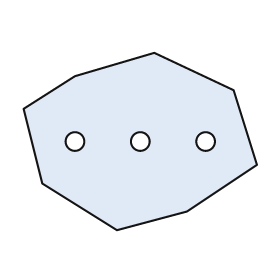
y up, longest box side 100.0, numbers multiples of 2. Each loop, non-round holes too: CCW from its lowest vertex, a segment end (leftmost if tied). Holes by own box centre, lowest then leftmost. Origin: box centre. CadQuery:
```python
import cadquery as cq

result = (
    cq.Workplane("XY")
    .moveTo(-10.0, -38.0)
    .lineTo(20.0, -30.0)
    .lineTo(50.0, -10.0)
    .lineTo(40.0, 22.0)
    .lineTo(6.0, 38.0)
    .lineTo(-28.0, 28.0)
    .lineTo(-50.0, 14.0)
    .lineTo(-42.0, -18.0)
    .close()
    .moveTo(-28.0, 0.0)
    .circle(4.0)
    .moveTo(0.0, 0.0)
    .circle(4.0)
    .moveTo(28.0, 0.0)
    .circle(4.0)
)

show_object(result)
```